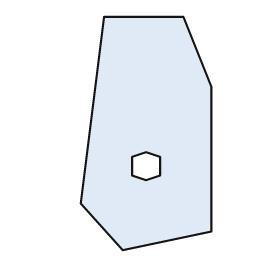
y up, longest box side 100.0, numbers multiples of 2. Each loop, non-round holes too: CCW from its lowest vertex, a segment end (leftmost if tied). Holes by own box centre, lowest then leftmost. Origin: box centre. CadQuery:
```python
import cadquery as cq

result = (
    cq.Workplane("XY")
    .moveTo(-10.0, -50.0)
    .lineTo(28.0, -42.0)
    .lineTo(28.0, 20.0)
    .lineTo(16.0, 50.0)
    .lineTo(-18.0, 50.0)
    .lineTo(-28.0, -30.0)
    .close()
    .moveTo(0.0, -20.0)
    .lineTo(6.0, -18.0)
    .lineTo(6.0, -10.0)
    .lineTo(0.0, -8.0)
    .lineTo(-6.0, -10.0)
    .lineTo(-6.0, -18.0)
    .close()
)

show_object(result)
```